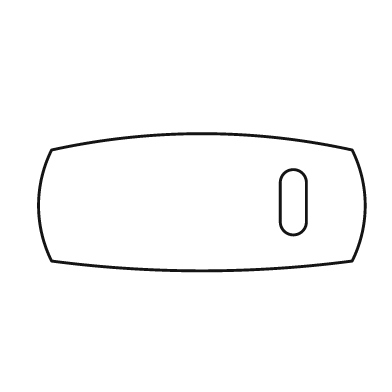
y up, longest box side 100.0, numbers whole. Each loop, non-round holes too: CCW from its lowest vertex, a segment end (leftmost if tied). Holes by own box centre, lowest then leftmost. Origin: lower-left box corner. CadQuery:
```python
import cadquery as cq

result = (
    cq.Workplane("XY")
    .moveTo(4.0, 3.0)
    .threePointArc((50.0, 0.0), (96.0, 3.0))
    .threePointArc((100.0, 20.0), (96.0, 37.0))
    .threePointArc((50.0, 42.0), (4.0, 37.0))
    .threePointArc((0.0, 20.0), (4.0, 3.0))
    .close()
    .moveTo(74.0, 15.0)
    .threePointArc((78.0, 11.0), (82.0, 15.0))
    .lineTo(82.0, 27.0)
    .threePointArc((78.0, 31.0), (74.0, 27.0))
    .close()
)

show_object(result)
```